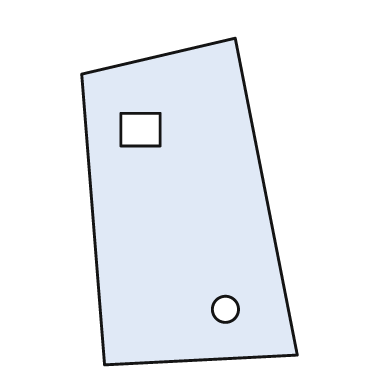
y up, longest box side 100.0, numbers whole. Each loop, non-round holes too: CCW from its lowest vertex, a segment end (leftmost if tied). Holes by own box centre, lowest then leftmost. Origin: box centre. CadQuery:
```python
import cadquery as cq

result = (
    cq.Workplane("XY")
    .moveTo(-26.0, -50.0)
    .lineTo(33.0, -47.0)
    .lineTo(14.0, 50.0)
    .lineTo(-33.0, 39.0)
    .close()
    .moveTo(11.0, -33.0)
    .circle(4.0)
    .moveTo(-21.0, 17.0)
    .lineTo(-9.0, 17.0)
    .lineTo(-9.0, 27.0)
    .lineTo(-21.0, 27.0)
    .close()
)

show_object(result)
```